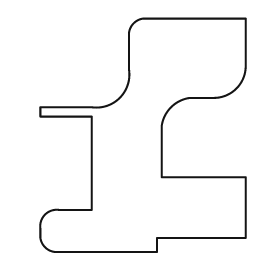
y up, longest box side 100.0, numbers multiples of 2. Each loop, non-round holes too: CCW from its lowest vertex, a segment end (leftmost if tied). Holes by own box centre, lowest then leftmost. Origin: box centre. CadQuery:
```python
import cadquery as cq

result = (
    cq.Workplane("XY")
    .moveTo(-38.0, -50.0)
    .lineTo(6.0, -50.0)
    .lineTo(6.0, -44.0)
    .lineTo(44.0, -44.0)
    .lineTo(44.0, -18.0)
    .lineTo(8.0, -18.0)
    .lineTo(8.0, 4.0)
    .threePointArc((12.0, 12.0), (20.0, 16.0))
    .lineTo(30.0, 16.0)
    .threePointArc((40.0, 20.0), (44.0, 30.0))
    .lineTo(44.0, 50.0)
    .lineTo(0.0, 50.0)
    .threePointArc((-4.0, 48.0), (-6.0, 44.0))
    .lineTo(-6.0, 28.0)
    .threePointArc((-10.0, 16.0), (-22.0, 12.0))
    .lineTo(-44.0, 12.0)
    .lineTo(-44.0, 8.0)
    .lineTo(-22.0, 8.0)
    .lineTo(-22.0, -32.0)
    .lineTo(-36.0, -32.0)
    .threePointArc((-42.0, -34.0), (-44.0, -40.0))
    .lineTo(-44.0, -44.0)
    .threePointArc((-42.0, -48.0), (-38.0, -50.0))
    .close()
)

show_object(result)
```